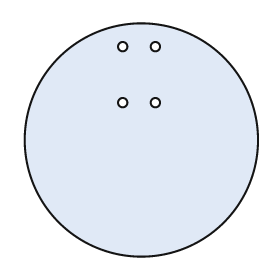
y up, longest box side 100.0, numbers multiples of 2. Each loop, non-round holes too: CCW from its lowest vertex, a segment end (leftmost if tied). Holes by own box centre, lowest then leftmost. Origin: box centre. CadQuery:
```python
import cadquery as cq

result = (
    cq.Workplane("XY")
    .moveTo(0.0, 0.0)
    .circle(50.0)
    .moveTo(-8.0, 16.0)
    .circle(2.0)
    .moveTo(6.0, 16.0)
    .circle(2.0)
    .moveTo(-8.0, 40.0)
    .circle(2.0)
    .moveTo(6.0, 40.0)
    .circle(2.0)
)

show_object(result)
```